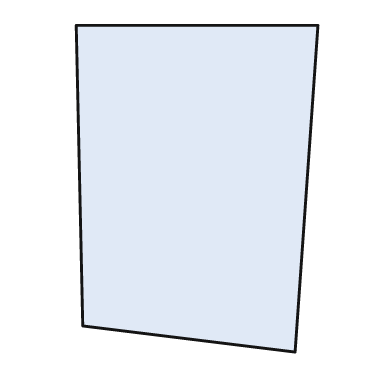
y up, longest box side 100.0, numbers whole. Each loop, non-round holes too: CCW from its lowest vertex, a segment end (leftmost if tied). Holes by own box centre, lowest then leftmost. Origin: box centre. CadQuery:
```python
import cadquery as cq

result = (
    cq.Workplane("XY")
    .moveTo(30.0, -50.0)
    .lineTo(37.0, 50.0)
    .lineTo(-37.0, 50.0)
    .lineTo(-35.0, -42.0)
    .close()
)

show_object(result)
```